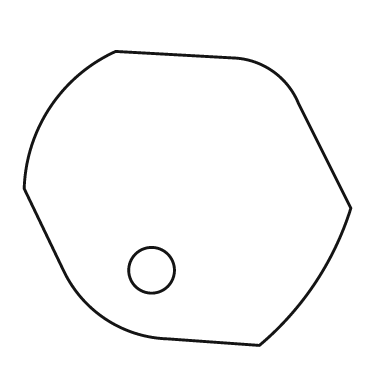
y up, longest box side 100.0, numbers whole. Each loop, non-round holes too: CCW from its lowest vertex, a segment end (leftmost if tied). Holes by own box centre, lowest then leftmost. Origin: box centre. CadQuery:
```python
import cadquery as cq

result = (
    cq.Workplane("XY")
    .moveTo(22.0, -45.0)
    .threePointArc((39.0, -26.0), (50.0, -3.0))
    .lineTo(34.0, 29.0)
    .threePointArc((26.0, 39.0), (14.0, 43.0))
    .lineTo(-22.0, 45.0)
    .threePointArc((-42.0, 28.0), (-50.0, 3.0))
    .lineTo(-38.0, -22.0)
    .threePointArc((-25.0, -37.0), (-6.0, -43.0))
    .close()
    .moveTo(-11.0, -22.0)
    .circle(7.0)
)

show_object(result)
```